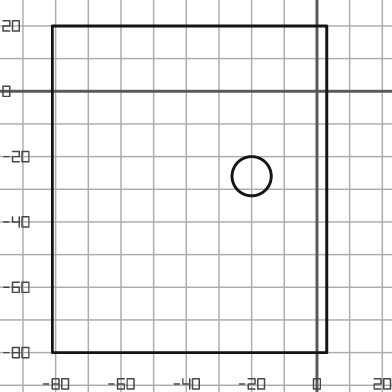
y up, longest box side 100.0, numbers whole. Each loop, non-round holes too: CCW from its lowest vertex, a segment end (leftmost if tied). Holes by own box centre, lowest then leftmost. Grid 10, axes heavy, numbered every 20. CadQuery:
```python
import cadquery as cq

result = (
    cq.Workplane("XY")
    .moveTo(-81.0, -80.0)
    .lineTo(3.0, -80.0)
    .lineTo(3.0, 20.0)
    .lineTo(-81.0, 20.0)
    .close()
    .moveTo(-20.0, -26.0)
    .circle(6.0)
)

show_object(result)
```